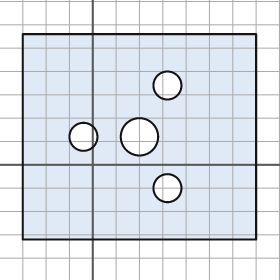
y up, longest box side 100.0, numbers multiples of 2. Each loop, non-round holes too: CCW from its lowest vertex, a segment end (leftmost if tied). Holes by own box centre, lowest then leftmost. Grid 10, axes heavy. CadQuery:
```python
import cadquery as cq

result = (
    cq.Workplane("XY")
    .moveTo(-30.0, -32.0)
    .lineTo(70.0, -32.0)
    .lineTo(70.0, 56.0)
    .lineTo(-30.0, 56.0)
    .close()
    .moveTo(32.0, -10.0)
    .circle(6.0)
    .moveTo(-4.0, 12.0)
    .circle(6.0)
    .moveTo(20.0, 12.0)
    .circle(8.0)
    .moveTo(32.0, 34.0)
    .circle(6.0)
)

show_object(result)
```